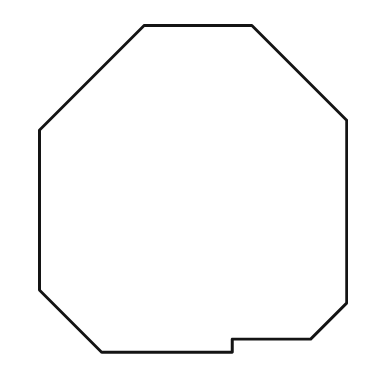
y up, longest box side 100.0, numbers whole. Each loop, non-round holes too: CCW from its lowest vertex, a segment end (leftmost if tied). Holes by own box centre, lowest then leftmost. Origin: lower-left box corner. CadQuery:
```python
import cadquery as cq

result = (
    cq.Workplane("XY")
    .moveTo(19.0, 0.0)
    .lineTo(59.0, 0.0)
    .lineTo(59.0, 4.0)
    .lineTo(83.0, 4.0)
    .lineTo(94.0, 15.0)
    .lineTo(94.0, 71.0)
    .lineTo(65.0, 100.0)
    .lineTo(32.0, 100.0)
    .lineTo(0.0, 68.0)
    .lineTo(0.0, 19.0)
    .close()
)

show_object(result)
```